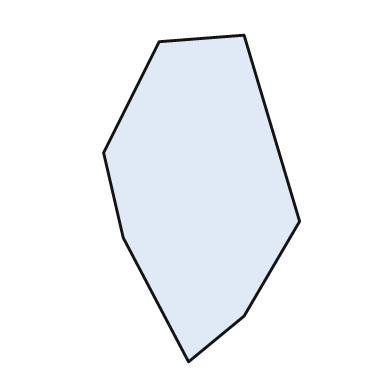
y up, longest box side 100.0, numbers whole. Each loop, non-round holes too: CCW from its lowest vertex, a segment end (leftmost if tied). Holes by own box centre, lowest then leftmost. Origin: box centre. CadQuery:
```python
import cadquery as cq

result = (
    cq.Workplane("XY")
    .moveTo(-4.0, -50.0)
    .lineTo(13.0, -36.0)
    .lineTo(30.0, -7.0)
    .lineTo(13.0, 50.0)
    .lineTo(-13.0, 48.0)
    .lineTo(-30.0, 14.0)
    .lineTo(-24.0, -12.0)
    .close()
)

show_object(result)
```